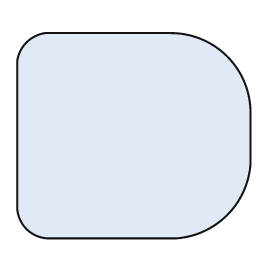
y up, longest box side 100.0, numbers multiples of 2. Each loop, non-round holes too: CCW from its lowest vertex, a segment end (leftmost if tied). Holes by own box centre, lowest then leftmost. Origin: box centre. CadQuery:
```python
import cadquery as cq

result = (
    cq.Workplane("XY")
    .moveTo(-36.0, -44.0)
    .lineTo(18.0, -44.0)
    .threePointArc((40.0, -34.0), (50.0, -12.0))
    .lineTo(50.0, 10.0)
    .threePointArc((40.0, 34.0), (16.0, 44.0))
    .lineTo(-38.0, 44.0)
    .threePointArc((-46.0, 40.0), (-50.0, 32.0))
    .lineTo(-50.0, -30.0)
    .threePointArc((-46.0, -40.0), (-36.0, -44.0))
    .close()
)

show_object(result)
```